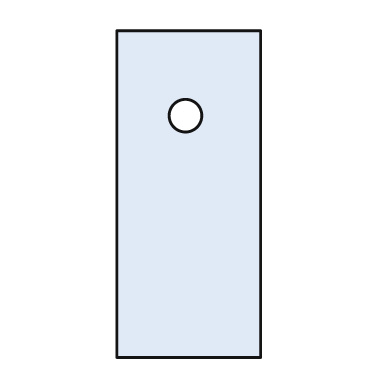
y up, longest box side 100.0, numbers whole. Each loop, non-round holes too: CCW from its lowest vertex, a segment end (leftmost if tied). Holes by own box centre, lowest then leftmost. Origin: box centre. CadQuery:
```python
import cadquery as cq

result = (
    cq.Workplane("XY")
    .moveTo(-22.0, -50.0)
    .lineTo(22.0, -50.0)
    .lineTo(22.0, 50.0)
    .lineTo(-22.0, 50.0)
    .close()
    .moveTo(-1.0, 24.0)
    .circle(5.0)
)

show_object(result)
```